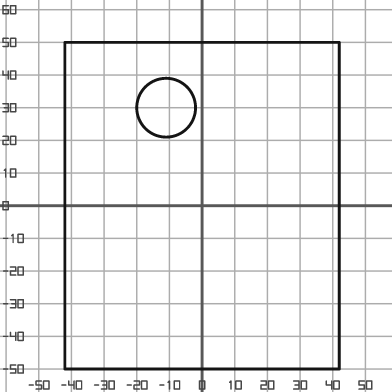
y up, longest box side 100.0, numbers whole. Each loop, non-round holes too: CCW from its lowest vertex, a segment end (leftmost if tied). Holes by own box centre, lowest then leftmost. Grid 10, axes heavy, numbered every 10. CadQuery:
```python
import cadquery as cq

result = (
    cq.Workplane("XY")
    .moveTo(-42.0, -50.0)
    .lineTo(42.0, -50.0)
    .lineTo(42.0, 50.0)
    .lineTo(-42.0, 50.0)
    .close()
    .moveTo(-11.0, 30.0)
    .circle(9.0)
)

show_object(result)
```